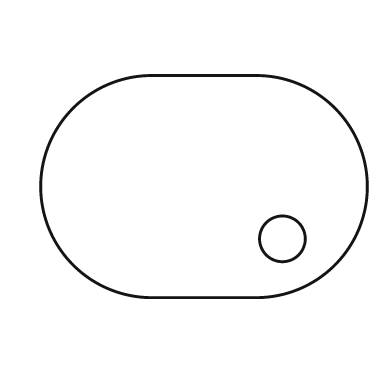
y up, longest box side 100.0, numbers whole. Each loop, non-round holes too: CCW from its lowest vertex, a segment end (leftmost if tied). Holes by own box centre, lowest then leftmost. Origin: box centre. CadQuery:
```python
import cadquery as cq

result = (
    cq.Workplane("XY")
    .moveTo(-16.0, -34.0)
    .lineTo(16.0, -34.0)
    .threePointArc((50.0, 0.0), (16.0, 34.0))
    .lineTo(-16.0, 34.0)
    .threePointArc((-50.0, 0.0), (-16.0, -34.0))
    .close()
    .moveTo(24.0, -16.0)
    .circle(7.0)
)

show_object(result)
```